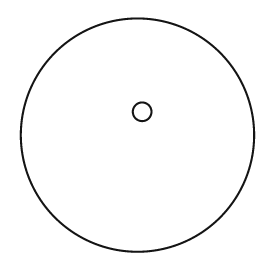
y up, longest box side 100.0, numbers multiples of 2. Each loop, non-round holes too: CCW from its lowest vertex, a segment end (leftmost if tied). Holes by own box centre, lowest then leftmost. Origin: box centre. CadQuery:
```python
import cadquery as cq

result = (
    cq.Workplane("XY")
    .moveTo(0.0, 0.0)
    .circle(50.0)
    .moveTo(2.0, 10.0)
    .circle(4.0)
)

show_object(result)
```